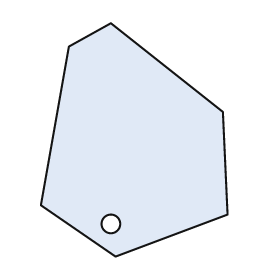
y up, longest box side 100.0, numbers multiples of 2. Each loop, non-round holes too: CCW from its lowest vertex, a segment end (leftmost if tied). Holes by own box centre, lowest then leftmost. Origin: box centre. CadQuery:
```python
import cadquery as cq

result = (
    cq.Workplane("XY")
    .moveTo(-8.0, -50.0)
    .lineTo(40.0, -32.0)
    .lineTo(38.0, 12.0)
    .lineTo(-10.0, 50.0)
    .lineTo(-28.0, 40.0)
    .lineTo(-40.0, -28.0)
    .close()
    .moveTo(-10.0, -36.0)
    .circle(4.0)
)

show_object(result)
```